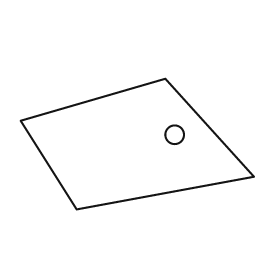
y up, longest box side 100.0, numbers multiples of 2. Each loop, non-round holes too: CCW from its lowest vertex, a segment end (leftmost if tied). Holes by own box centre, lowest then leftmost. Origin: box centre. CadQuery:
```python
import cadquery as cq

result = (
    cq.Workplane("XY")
    .moveTo(-26.0, -28.0)
    .lineTo(50.0, -14.0)
    .lineTo(12.0, 28.0)
    .lineTo(-50.0, 10.0)
    .close()
    .moveTo(16.0, 4.0)
    .circle(4.0)
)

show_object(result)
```